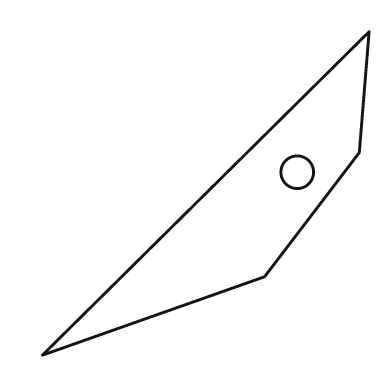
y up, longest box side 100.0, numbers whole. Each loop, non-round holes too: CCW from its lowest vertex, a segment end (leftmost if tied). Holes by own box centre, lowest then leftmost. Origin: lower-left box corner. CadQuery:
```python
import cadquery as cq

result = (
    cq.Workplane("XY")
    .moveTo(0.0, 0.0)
    .lineTo(68.0, 24.0)
    .lineTo(97.0, 62.0)
    .lineTo(100.0, 99.0)
    .close()
    .moveTo(78.0, 56.0)
    .circle(5.0)
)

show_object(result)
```